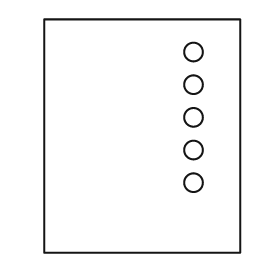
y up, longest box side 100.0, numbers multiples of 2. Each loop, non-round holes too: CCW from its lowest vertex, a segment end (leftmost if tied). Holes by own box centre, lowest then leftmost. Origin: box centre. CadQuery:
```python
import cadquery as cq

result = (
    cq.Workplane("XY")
    .moveTo(-42.0, -50.0)
    .lineTo(42.0, -50.0)
    .lineTo(42.0, 50.0)
    .lineTo(-42.0, 50.0)
    .close()
    .moveTo(22.0, -20.0)
    .circle(4.0)
    .moveTo(22.0, -6.0)
    .circle(4.0)
    .moveTo(22.0, 8.0)
    .circle(4.0)
    .moveTo(22.0, 22.0)
    .circle(4.0)
    .moveTo(22.0, 36.0)
    .circle(4.0)
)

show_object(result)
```